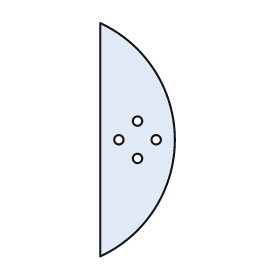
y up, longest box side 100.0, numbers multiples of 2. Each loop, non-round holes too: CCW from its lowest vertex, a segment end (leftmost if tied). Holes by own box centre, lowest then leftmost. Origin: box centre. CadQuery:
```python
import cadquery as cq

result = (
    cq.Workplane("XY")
    .moveTo(-16.0, -50.0)
    .threePointArc((16.0, 0.0), (-16.0, 50.0))
    .close()
    .moveTo(0.0, -8.0)
    .circle(2.0)
    .moveTo(-8.0, 0.0)
    .circle(2.0)
    .moveTo(8.0, 0.0)
    .circle(2.0)
    .moveTo(0.0, 8.0)
    .circle(2.0)
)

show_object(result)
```